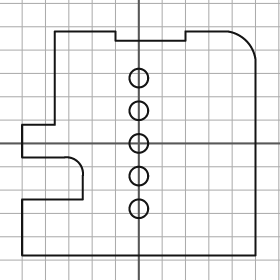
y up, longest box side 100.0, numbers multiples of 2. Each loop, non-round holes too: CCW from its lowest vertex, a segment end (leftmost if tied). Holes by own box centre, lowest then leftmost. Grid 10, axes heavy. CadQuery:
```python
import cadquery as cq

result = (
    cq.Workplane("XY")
    .moveTo(-50.0, -48.0)
    .lineTo(50.0, -48.0)
    .lineTo(50.0, 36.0)
    .threePointArc((46.0, 44.0), (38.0, 48.0))
    .lineTo(20.0, 48.0)
    .lineTo(20.0, 44.0)
    .lineTo(-10.0, 44.0)
    .lineTo(-10.0, 48.0)
    .lineTo(-36.0, 48.0)
    .lineTo(-36.0, 8.0)
    .lineTo(-50.0, 8.0)
    .lineTo(-50.0, -6.0)
    .lineTo(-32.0, -6.0)
    .threePointArc((-26.0, -8.0), (-24.0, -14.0))
    .lineTo(-24.0, -24.0)
    .lineTo(-50.0, -24.0)
    .close()
    .moveTo(0.0, -28.0)
    .circle(4.0)
    .moveTo(0.0, -14.0)
    .circle(4.0)
    .moveTo(0.0, 0.0)
    .circle(4.0)
    .moveTo(0.0, 14.0)
    .circle(4.0)
    .moveTo(0.0, 28.0)
    .circle(4.0)
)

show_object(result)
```